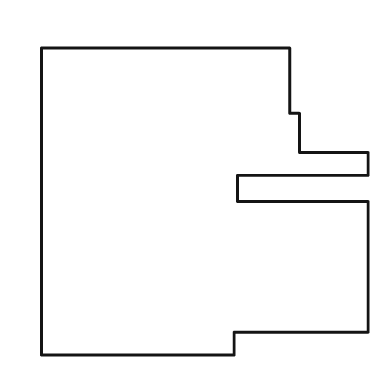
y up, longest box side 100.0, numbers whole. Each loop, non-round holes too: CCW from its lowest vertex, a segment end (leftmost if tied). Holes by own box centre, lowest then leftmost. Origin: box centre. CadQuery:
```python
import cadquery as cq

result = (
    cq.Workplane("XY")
    .moveTo(-50.0, -47.0)
    .lineTo(9.0, -47.0)
    .lineTo(9.0, -40.0)
    .lineTo(50.0, -40.0)
    .lineTo(50.0, 0.0)
    .lineTo(10.0, 0.0)
    .lineTo(10.0, 8.0)
    .lineTo(50.0, 8.0)
    .lineTo(50.0, 15.0)
    .lineTo(29.0, 15.0)
    .lineTo(29.0, 27.0)
    .lineTo(26.0, 27.0)
    .lineTo(26.0, 47.0)
    .lineTo(-50.0, 47.0)
    .close()
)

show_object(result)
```